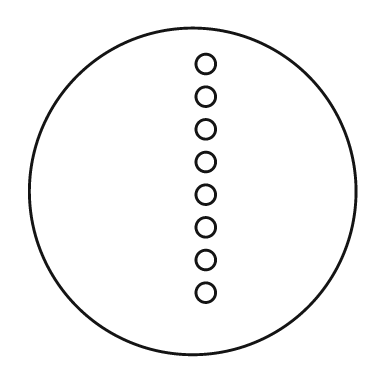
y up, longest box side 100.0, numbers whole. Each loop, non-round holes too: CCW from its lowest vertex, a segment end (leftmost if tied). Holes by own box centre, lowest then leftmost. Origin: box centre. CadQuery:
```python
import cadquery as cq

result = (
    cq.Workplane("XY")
    .moveTo(0.0, 0.0)
    .circle(50.0)
    .moveTo(4.0, -31.0)
    .circle(3.0)
    .moveTo(4.0, -21.0)
    .circle(3.0)
    .moveTo(4.0, -11.0)
    .circle(3.0)
    .moveTo(4.0, -1.0)
    .circle(3.0)
    .moveTo(4.0, 9.0)
    .circle(3.0)
    .moveTo(4.0, 19.0)
    .circle(3.0)
    .moveTo(4.0, 29.0)
    .circle(3.0)
    .moveTo(4.0, 39.0)
    .circle(3.0)
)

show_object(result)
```